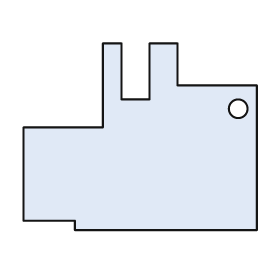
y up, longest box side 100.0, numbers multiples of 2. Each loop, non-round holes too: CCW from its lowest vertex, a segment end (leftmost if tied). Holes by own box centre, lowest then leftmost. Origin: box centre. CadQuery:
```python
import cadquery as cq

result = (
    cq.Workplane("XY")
    .moveTo(-28.0, -40.0)
    .lineTo(50.0, -40.0)
    .lineTo(50.0, 22.0)
    .lineTo(16.0, 22.0)
    .lineTo(16.0, 40.0)
    .lineTo(4.0, 40.0)
    .lineTo(4.0, 16.0)
    .lineTo(-8.0, 16.0)
    .lineTo(-8.0, 40.0)
    .lineTo(-16.0, 40.0)
    .lineTo(-16.0, 4.0)
    .lineTo(-50.0, 4.0)
    .lineTo(-50.0, -36.0)
    .lineTo(-28.0, -36.0)
    .close()
    .moveTo(42.0, 12.0)
    .circle(4.0)
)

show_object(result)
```